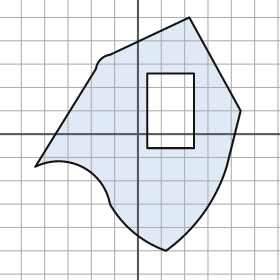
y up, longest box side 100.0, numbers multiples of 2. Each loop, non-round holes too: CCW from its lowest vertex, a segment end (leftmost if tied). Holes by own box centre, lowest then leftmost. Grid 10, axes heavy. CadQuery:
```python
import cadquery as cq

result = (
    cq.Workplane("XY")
    .moveTo(12.0, -50.0)
    .threePointArc((28.0, -34.0), (38.0, -14.0))
    .lineTo(44.0, 10.0)
    .lineTo(22.0, 50.0)
    .lineTo(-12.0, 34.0)
    .threePointArc((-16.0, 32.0), (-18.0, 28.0))
    .lineTo(-44.0, -14.0)
    .threePointArc((-24.0, -14.0), (-12.0, -30.0))
    .threePointArc((-2.0, -42.0), (12.0, -50.0))
    .close()
    .moveTo(4.0, -6.0)
    .lineTo(24.0, -6.0)
    .lineTo(24.0, 26.0)
    .lineTo(4.0, 26.0)
    .close()
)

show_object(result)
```